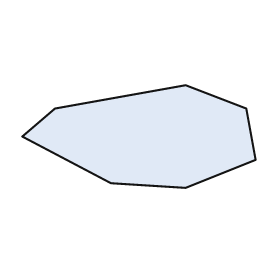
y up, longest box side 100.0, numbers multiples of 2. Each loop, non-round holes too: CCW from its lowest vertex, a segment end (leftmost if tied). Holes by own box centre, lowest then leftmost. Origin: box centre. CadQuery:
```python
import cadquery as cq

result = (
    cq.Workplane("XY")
    .moveTo(20.0, -22.0)
    .lineTo(50.0, -10.0)
    .lineTo(46.0, 12.0)
    .lineTo(20.0, 22.0)
    .lineTo(-36.0, 12.0)
    .lineTo(-50.0, 0.0)
    .lineTo(-12.0, -20.0)
    .close()
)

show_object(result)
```